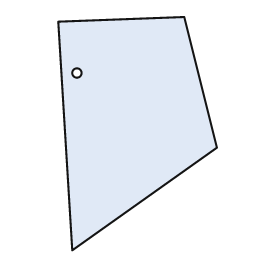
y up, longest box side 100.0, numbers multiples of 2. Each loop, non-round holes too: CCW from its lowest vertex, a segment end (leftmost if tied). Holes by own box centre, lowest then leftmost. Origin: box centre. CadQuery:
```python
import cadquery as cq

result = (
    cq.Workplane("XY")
    .moveTo(-28.0, -50.0)
    .lineTo(34.0, -6.0)
    .lineTo(20.0, 50.0)
    .lineTo(-34.0, 48.0)
    .close()
    .moveTo(-26.0, 26.0)
    .circle(2.0)
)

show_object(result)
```